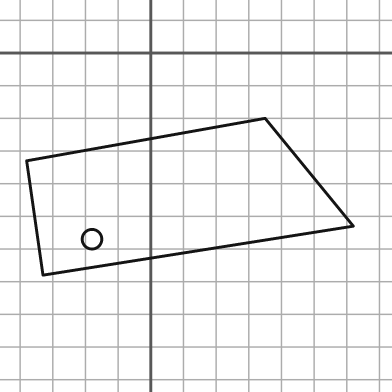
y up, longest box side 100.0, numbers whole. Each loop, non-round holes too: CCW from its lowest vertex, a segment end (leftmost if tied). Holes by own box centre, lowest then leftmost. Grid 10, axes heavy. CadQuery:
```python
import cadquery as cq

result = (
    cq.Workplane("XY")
    .moveTo(-33.0, -68.0)
    .lineTo(62.0, -53.0)
    .lineTo(35.0, -20.0)
    .lineTo(-38.0, -33.0)
    .close()
    .moveTo(-18.0, -57.0)
    .circle(3.0)
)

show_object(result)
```